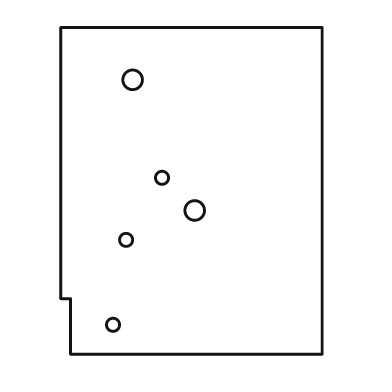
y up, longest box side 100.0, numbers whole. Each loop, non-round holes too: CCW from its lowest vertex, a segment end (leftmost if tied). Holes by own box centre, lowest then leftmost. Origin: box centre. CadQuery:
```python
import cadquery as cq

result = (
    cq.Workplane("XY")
    .moveTo(-37.0, -50.0)
    .lineTo(40.0, -50.0)
    .lineTo(40.0, 50.0)
    .lineTo(-40.0, 50.0)
    .lineTo(-40.0, -33.0)
    .lineTo(-37.0, -33.0)
    .close()
    .moveTo(-24.0, -41.0)
    .circle(2.0)
    .moveTo(-20.0, -15.0)
    .circle(2.0)
    .moveTo(1.0, -6.0)
    .circle(3.0)
    .moveTo(-9.0, 4.0)
    .circle(2.0)
    .moveTo(-18.0, 34.0)
    .circle(3.0)
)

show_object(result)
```